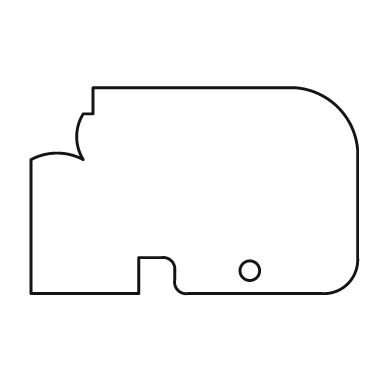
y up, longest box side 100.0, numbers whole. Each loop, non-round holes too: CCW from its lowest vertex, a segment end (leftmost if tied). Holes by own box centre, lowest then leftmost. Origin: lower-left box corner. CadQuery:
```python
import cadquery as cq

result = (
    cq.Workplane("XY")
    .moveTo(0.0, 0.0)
    .lineTo(33.0, 0.0)
    .lineTo(33.0, 11.0)
    .lineTo(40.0, 11.0)
    .threePointArc((43.0, 10.0), (44.0, 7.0))
    .lineTo(44.0, 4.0)
    .threePointArc((45.0, 1.0), (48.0, 0.0))
    .lineTo(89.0, 0.0)
    .threePointArc((97.0, 3.0), (100.0, 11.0))
    .lineTo(100.0, 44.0)
    .threePointArc((94.0, 57.0), (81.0, 63.0))
    .lineTo(19.0, 63.0)
    .lineTo(19.0, 55.0)
    .lineTo(16.0, 55.0)
    .threePointArc((14.0, 48.0), (16.0, 41.0))
    .threePointArc((8.0, 43.0), (0.0, 41.0))
    .close()
    .moveTo(67.0, 7.0)
    .circle(3.0)
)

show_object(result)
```